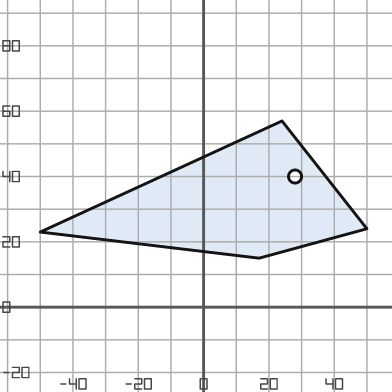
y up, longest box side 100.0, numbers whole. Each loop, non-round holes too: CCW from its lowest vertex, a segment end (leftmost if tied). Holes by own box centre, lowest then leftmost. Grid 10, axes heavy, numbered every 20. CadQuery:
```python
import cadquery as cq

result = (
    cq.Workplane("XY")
    .moveTo(17.0, 15.0)
    .lineTo(50.0, 24.0)
    .lineTo(24.0, 57.0)
    .lineTo(-50.0, 23.0)
    .close()
    .moveTo(28.0, 40.0)
    .circle(2.0)
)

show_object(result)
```